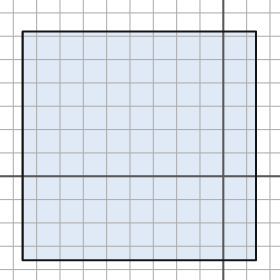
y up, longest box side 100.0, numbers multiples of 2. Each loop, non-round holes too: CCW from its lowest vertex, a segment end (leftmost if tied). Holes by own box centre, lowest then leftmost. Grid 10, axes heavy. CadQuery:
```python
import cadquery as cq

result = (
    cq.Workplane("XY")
    .moveTo(-86.0, -36.0)
    .lineTo(14.0, -36.0)
    .lineTo(14.0, 62.0)
    .lineTo(-86.0, 62.0)
    .close()
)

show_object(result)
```